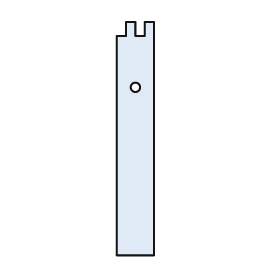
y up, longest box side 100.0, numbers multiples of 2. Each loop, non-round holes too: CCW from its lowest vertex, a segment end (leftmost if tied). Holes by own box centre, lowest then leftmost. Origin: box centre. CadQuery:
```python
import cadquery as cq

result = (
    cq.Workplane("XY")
    .moveTo(-8.0, -50.0)
    .lineTo(8.0, -50.0)
    .lineTo(8.0, 50.0)
    .lineTo(4.0, 50.0)
    .lineTo(4.0, 44.0)
    .lineTo(0.0, 44.0)
    .lineTo(0.0, 50.0)
    .lineTo(-4.0, 50.0)
    .lineTo(-4.0, 44.0)
    .lineTo(-8.0, 44.0)
    .close()
    .moveTo(0.0, 22.0)
    .circle(2.0)
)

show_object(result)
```